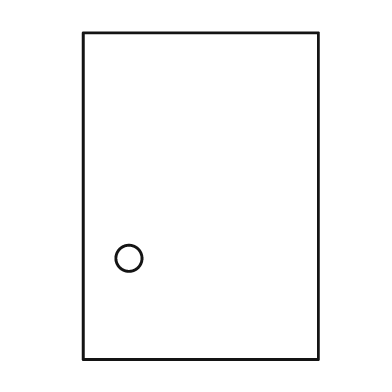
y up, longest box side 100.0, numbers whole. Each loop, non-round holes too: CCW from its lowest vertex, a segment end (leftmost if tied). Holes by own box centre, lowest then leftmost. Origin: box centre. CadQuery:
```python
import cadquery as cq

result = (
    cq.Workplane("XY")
    .moveTo(-36.0, -50.0)
    .lineTo(36.0, -50.0)
    .lineTo(36.0, 50.0)
    .lineTo(-36.0, 50.0)
    .close()
    .moveTo(-22.0, -19.0)
    .circle(4.0)
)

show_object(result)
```